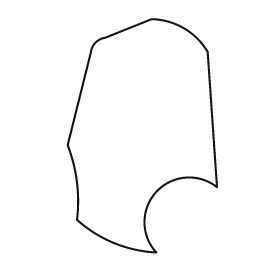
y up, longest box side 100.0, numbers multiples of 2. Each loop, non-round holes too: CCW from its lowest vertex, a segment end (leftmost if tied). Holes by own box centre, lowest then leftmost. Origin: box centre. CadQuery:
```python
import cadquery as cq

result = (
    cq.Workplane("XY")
    .moveTo(6.0, -50.0)
    .threePointArc((6.0, -24.0), (32.0, -22.0))
    .lineTo(28.0, 36.0)
    .threePointArc((18.0, 46.0), (4.0, 50.0))
    .lineTo(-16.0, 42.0)
    .threePointArc((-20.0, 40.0), (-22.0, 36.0))
    .lineTo(-32.0, -4.0)
    .threePointArc((-28.0, -20.0), (-28.0, -36.0))
    .threePointArc((-12.0, -46.0), (6.0, -50.0))
    .close()
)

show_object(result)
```